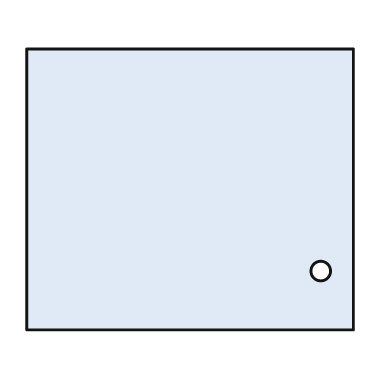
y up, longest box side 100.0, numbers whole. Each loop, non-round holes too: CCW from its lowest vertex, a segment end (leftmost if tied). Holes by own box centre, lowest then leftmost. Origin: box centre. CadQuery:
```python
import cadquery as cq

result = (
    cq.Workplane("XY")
    .moveTo(-50.0, -43.0)
    .lineTo(50.0, -43.0)
    .lineTo(50.0, 43.0)
    .lineTo(-50.0, 43.0)
    .close()
    .moveTo(40.0, -25.0)
    .circle(3.0)
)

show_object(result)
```